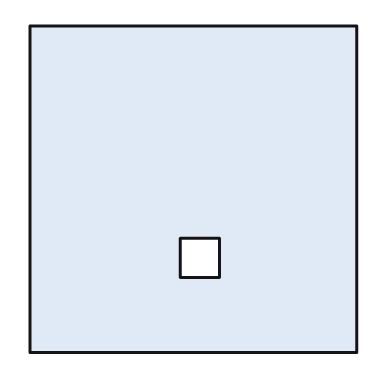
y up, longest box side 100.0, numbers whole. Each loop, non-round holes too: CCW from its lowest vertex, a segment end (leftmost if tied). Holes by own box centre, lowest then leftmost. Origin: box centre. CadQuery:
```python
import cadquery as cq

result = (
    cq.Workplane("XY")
    .moveTo(-50.0, -50.0)
    .lineTo(50.0, -50.0)
    .lineTo(50.0, 50.0)
    .lineTo(-50.0, 50.0)
    .close()
    .moveTo(-4.0, -27.0)
    .lineTo(8.0, -27.0)
    .lineTo(8.0, -15.0)
    .lineTo(-4.0, -15.0)
    .close()
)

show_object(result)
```